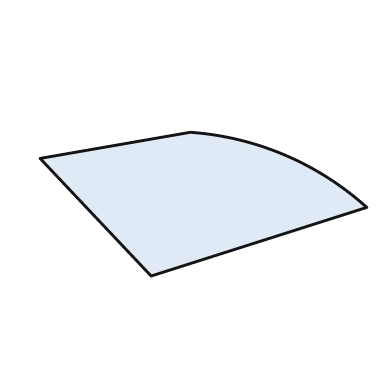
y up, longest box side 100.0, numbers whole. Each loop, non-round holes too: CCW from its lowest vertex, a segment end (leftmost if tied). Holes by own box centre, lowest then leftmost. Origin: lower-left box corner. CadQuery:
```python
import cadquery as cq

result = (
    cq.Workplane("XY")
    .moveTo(34.0, 0.0)
    .lineTo(100.0, 21.0)
    .threePointArc((75.0, 37.0), (46.0, 44.0))
    .lineTo(0.0, 36.0)
    .close()
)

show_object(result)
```